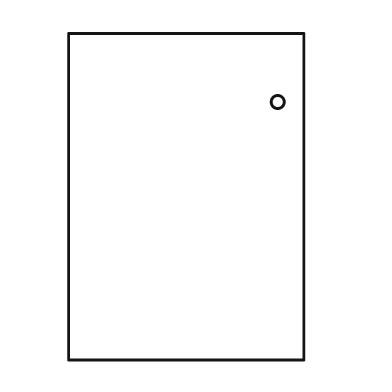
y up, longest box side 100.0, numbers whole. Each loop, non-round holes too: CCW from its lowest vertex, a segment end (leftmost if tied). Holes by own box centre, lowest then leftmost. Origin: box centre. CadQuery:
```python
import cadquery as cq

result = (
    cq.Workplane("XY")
    .moveTo(-36.0, -50.0)
    .lineTo(36.0, -50.0)
    .lineTo(36.0, 50.0)
    .lineTo(-36.0, 50.0)
    .close()
    .moveTo(28.0, 29.0)
    .circle(2.0)
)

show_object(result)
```